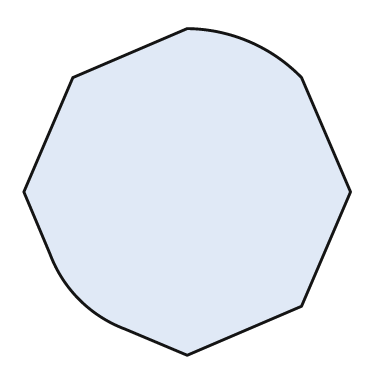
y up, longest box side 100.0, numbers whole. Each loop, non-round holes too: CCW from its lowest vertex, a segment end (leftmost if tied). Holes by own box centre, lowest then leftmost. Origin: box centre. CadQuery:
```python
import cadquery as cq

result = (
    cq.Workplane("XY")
    .moveTo(0.0, -50.0)
    .lineTo(35.0, -35.0)
    .lineTo(50.0, 0.0)
    .lineTo(35.0, 35.0)
    .threePointArc((19.0, 46.0), (0.0, 50.0))
    .lineTo(-35.0, 35.0)
    .lineTo(-50.0, 0.0)
    .lineTo(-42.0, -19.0)
    .threePointArc((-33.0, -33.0), (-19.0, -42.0))
    .close()
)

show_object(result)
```